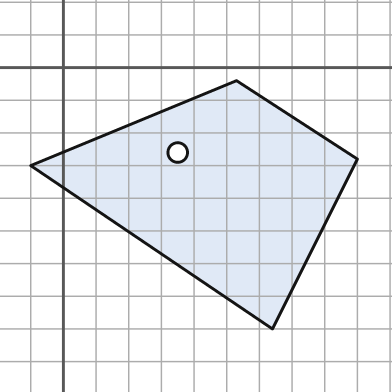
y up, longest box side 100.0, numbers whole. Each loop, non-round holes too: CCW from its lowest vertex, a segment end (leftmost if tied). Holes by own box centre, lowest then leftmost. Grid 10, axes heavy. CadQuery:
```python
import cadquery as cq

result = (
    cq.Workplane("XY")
    .moveTo(64.0, -80.0)
    .lineTo(90.0, -28.0)
    .lineTo(53.0, -4.0)
    .lineTo(-10.0, -30.0)
    .close()
    .moveTo(35.0, -26.0)
    .circle(3.0)
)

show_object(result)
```